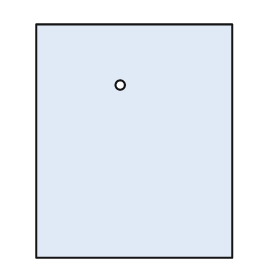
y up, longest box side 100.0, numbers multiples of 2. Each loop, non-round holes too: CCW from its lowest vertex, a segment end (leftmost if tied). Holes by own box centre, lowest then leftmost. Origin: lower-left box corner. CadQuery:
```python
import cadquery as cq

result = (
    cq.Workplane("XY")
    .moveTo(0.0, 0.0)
    .lineTo(84.0, 0.0)
    .lineTo(84.0, 100.0)
    .lineTo(0.0, 100.0)
    .close()
    .moveTo(36.0, 74.0)
    .circle(2.0)
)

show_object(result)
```